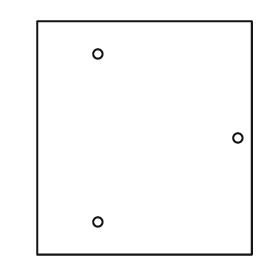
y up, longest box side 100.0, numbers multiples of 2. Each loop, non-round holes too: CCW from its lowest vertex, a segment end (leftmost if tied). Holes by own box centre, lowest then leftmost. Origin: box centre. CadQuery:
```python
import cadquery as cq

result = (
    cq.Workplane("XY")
    .moveTo(-46.0, -50.0)
    .lineTo(46.0, -50.0)
    .lineTo(46.0, 50.0)
    .lineTo(-46.0, 50.0)
    .close()
    .moveTo(-20.0, -36.0)
    .circle(2.0)
    .moveTo(40.0, 0.0)
    .circle(2.0)
    .moveTo(-20.0, 36.0)
    .circle(2.0)
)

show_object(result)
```